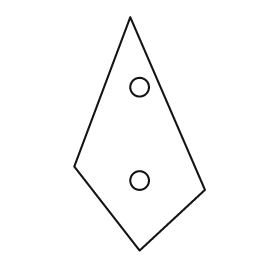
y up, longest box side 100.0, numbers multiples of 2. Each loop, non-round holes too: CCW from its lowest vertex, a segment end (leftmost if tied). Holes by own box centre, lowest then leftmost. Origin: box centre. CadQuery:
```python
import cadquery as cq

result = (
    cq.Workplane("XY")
    .moveTo(0.0, -50.0)
    .lineTo(28.0, -24.0)
    .lineTo(-4.0, 50.0)
    .lineTo(-28.0, -14.0)
    .close()
    .moveTo(0.0, -20.0)
    .circle(4.0)
    .moveTo(0.0, 20.0)
    .circle(4.0)
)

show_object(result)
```